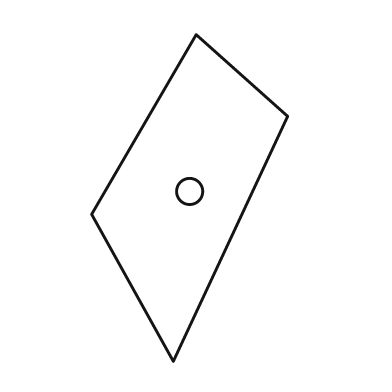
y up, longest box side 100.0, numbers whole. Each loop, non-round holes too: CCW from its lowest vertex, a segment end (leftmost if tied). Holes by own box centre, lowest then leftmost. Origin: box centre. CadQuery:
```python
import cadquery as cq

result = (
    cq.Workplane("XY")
    .moveTo(-5.0, -50.0)
    .lineTo(30.0, 25.0)
    .lineTo(2.0, 50.0)
    .lineTo(-30.0, -5.0)
    .close()
    .moveTo(0.0, 2.0)
    .circle(4.0)
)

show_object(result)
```